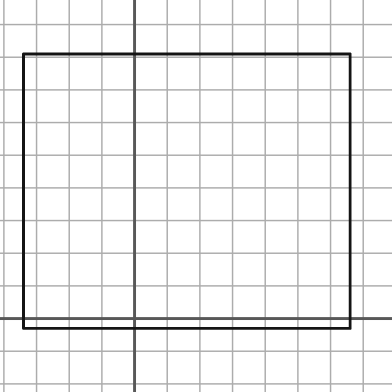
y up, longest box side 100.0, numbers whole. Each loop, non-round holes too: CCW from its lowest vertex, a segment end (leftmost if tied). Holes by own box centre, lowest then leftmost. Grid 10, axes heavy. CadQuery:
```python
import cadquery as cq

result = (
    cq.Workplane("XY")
    .moveTo(-34.0, -3.0)
    .lineTo(66.0, -3.0)
    .lineTo(66.0, 81.0)
    .lineTo(-34.0, 81.0)
    .close()
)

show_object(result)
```